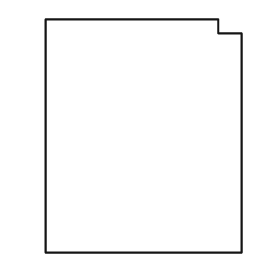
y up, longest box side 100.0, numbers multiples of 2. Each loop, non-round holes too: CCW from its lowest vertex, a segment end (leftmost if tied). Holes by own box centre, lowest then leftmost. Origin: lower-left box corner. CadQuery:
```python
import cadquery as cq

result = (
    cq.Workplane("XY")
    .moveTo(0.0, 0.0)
    .lineTo(84.0, 0.0)
    .lineTo(84.0, 94.0)
    .lineTo(74.0, 94.0)
    .lineTo(74.0, 100.0)
    .lineTo(0.0, 100.0)
    .close()
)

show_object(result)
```